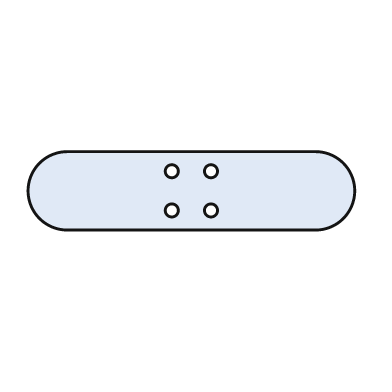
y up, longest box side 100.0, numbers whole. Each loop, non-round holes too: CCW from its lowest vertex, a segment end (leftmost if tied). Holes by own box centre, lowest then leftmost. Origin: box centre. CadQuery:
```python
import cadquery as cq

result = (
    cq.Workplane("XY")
    .moveTo(-38.0, -12.0)
    .lineTo(38.0, -12.0)
    .threePointArc((50.0, 0.0), (38.0, 12.0))
    .lineTo(-38.0, 12.0)
    .threePointArc((-50.0, 0.0), (-38.0, -12.0))
    .close()
    .moveTo(-6.0, -6.0)
    .circle(2.0)
    .moveTo(6.0, -6.0)
    .circle(2.0)
    .moveTo(-6.0, 6.0)
    .circle(2.0)
    .moveTo(6.0, 6.0)
    .circle(2.0)
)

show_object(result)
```